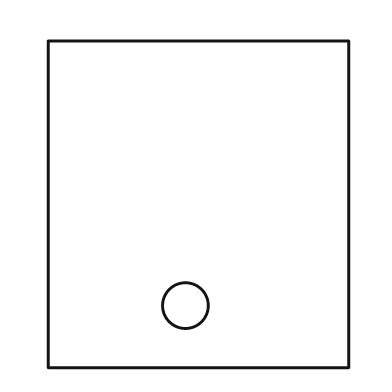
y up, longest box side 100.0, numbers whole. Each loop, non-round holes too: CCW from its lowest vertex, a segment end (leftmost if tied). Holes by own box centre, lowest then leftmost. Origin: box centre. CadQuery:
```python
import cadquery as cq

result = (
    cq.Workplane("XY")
    .moveTo(-46.0, -50.0)
    .lineTo(46.0, -50.0)
    .lineTo(46.0, 50.0)
    .lineTo(-46.0, 50.0)
    .close()
    .moveTo(-4.0, -31.0)
    .circle(7.0)
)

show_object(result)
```